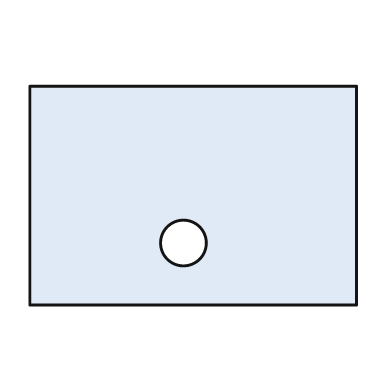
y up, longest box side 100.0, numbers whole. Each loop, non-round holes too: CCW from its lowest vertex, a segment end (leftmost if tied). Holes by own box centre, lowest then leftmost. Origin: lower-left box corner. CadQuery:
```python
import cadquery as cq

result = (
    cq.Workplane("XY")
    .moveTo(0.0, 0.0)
    .lineTo(100.0, 0.0)
    .lineTo(100.0, 67.0)
    .lineTo(0.0, 67.0)
    .close()
    .moveTo(47.0, 19.0)
    .circle(7.0)
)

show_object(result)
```